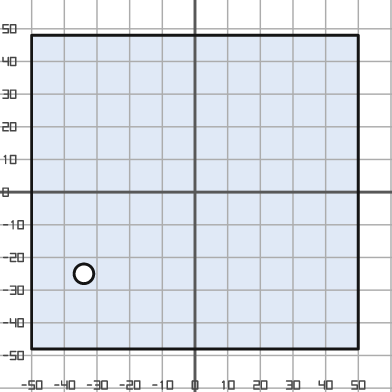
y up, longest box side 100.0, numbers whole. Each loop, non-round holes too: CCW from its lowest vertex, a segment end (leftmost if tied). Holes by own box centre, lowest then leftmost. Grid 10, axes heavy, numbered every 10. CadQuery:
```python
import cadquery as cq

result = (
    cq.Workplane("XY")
    .moveTo(-50.0, -48.0)
    .lineTo(50.0, -48.0)
    .lineTo(50.0, 48.0)
    .lineTo(-50.0, 48.0)
    .close()
    .moveTo(-34.0, -25.0)
    .circle(3.0)
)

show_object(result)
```